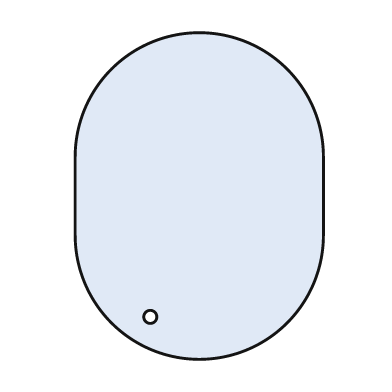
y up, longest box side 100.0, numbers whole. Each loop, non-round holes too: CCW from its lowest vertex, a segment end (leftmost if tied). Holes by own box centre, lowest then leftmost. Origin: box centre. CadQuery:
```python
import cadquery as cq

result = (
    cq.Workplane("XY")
    .moveTo(-38.0, -12.0)
    .threePointArc((0.0, -50.0), (38.0, -12.0))
    .lineTo(38.0, 12.0)
    .threePointArc((0.0, 50.0), (-38.0, 12.0))
    .close()
    .moveTo(-15.0, -37.0)
    .circle(2.0)
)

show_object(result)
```